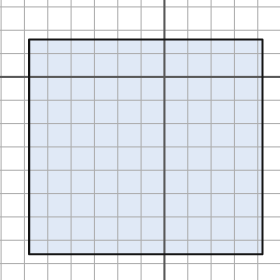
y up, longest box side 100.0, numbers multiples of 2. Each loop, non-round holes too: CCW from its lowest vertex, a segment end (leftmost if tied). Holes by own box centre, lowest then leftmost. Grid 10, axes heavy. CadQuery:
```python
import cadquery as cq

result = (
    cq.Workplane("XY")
    .moveTo(-58.0, -76.0)
    .lineTo(42.0, -76.0)
    .lineTo(42.0, 16.0)
    .lineTo(-58.0, 16.0)
    .close()
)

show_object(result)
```